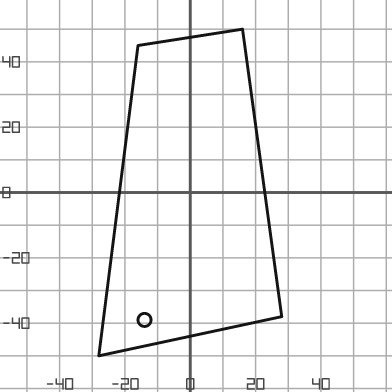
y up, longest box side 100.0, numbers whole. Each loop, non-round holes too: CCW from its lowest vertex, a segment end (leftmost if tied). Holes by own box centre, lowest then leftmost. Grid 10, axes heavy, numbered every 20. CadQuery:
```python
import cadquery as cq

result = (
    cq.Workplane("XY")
    .moveTo(-28.0, -50.0)
    .lineTo(28.0, -38.0)
    .lineTo(16.0, 50.0)
    .lineTo(-16.0, 45.0)
    .close()
    .moveTo(-14.0, -39.0)
    .circle(2.0)
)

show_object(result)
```